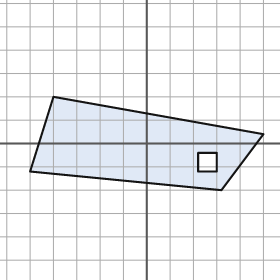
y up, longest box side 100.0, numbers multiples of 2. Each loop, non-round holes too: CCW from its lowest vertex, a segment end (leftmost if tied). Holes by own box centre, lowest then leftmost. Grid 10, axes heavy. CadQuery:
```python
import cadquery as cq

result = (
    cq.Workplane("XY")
    .moveTo(32.0, -20.0)
    .lineTo(50.0, 4.0)
    .lineTo(-40.0, 20.0)
    .lineTo(-50.0, -12.0)
    .close()
    .moveTo(22.0, -12.0)
    .lineTo(30.0, -12.0)
    .lineTo(30.0, -4.0)
    .lineTo(22.0, -4.0)
    .close()
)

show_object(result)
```